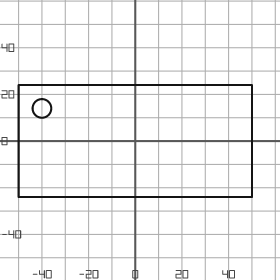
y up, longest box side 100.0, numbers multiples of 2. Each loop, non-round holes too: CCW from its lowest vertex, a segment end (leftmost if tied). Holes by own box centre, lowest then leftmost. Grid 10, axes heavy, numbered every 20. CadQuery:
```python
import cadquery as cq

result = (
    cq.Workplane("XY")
    .moveTo(-50.0, -24.0)
    .lineTo(50.0, -24.0)
    .lineTo(50.0, 24.0)
    .lineTo(-50.0, 24.0)
    .close()
    .moveTo(-40.0, 14.0)
    .circle(4.0)
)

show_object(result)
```